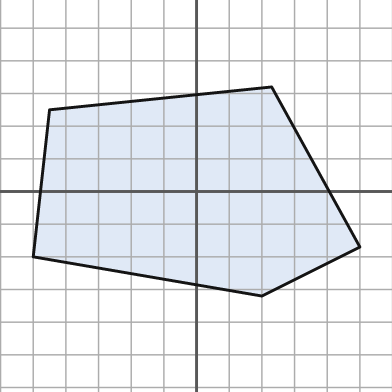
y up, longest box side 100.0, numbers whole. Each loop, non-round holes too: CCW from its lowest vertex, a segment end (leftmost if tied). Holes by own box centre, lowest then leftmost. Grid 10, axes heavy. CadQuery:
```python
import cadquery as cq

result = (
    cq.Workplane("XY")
    .moveTo(20.0, -32.0)
    .lineTo(50.0, -17.0)
    .lineTo(23.0, 32.0)
    .lineTo(-45.0, 25.0)
    .lineTo(-50.0, -20.0)
    .close()
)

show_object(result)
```